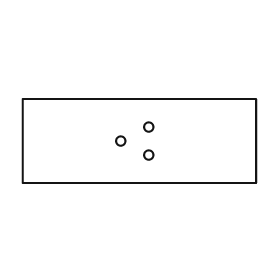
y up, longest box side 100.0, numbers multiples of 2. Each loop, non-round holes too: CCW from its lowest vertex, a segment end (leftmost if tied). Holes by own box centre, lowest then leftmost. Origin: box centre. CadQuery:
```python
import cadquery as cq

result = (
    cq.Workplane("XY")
    .moveTo(-50.0, -18.0)
    .lineTo(50.0, -18.0)
    .lineTo(50.0, 18.0)
    .lineTo(-50.0, 18.0)
    .close()
    .moveTo(4.0, -6.0)
    .circle(2.0)
    .moveTo(-8.0, 0.0)
    .circle(2.0)
    .moveTo(4.0, 6.0)
    .circle(2.0)
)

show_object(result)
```